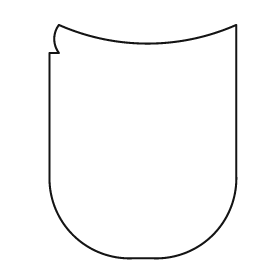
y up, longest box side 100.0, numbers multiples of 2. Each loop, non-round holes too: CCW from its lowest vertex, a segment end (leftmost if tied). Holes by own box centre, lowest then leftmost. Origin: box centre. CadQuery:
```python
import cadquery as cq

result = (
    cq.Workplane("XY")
    .moveTo(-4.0, -50.0)
    .lineTo(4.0, -50.0)
    .threePointArc((30.0, -40.0), (40.0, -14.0))
    .lineTo(40.0, 50.0)
    .threePointArc((2.0, 42.0), (-36.0, 50.0))
    .threePointArc((-38.0, 44.0), (-36.0, 38.0))
    .lineTo(-40.0, 38.0)
    .lineTo(-40.0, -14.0)
    .threePointArc((-30.0, -40.0), (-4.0, -50.0))
    .close()
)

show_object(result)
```